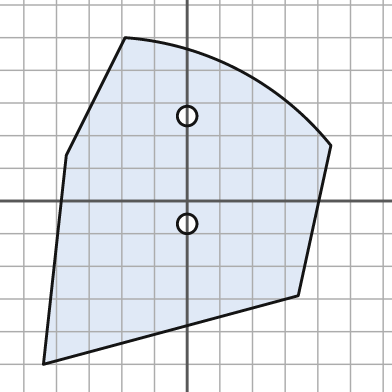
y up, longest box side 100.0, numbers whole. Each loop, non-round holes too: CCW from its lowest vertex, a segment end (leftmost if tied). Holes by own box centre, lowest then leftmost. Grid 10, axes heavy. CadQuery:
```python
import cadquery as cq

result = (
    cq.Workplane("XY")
    .moveTo(-44.0, -50.0)
    .lineTo(34.0, -29.0)
    .lineTo(44.0, 17.0)
    .threePointArc((16.0, 40.0), (-19.0, 50.0))
    .lineTo(-37.0, 14.0)
    .close()
    .moveTo(0.0, -7.0)
    .circle(3.0)
    .moveTo(0.0, 26.0)
    .circle(3.0)
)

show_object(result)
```